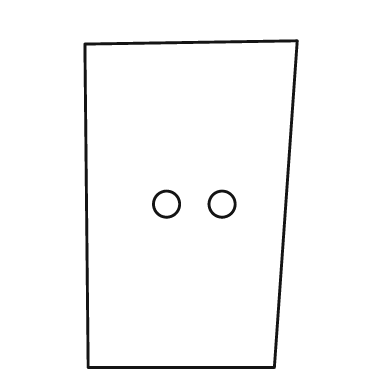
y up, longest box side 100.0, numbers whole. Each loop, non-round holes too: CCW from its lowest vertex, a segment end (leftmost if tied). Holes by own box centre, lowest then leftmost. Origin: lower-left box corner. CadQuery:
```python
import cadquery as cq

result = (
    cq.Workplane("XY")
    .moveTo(1.0, 0.0)
    .lineTo(58.0, 0.0)
    .lineTo(65.0, 100.0)
    .lineTo(0.0, 99.0)
    .close()
    .moveTo(25.0, 50.0)
    .circle(4.0)
    .moveTo(42.0, 50.0)
    .circle(4.0)
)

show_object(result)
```